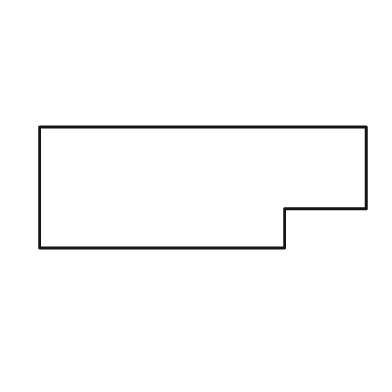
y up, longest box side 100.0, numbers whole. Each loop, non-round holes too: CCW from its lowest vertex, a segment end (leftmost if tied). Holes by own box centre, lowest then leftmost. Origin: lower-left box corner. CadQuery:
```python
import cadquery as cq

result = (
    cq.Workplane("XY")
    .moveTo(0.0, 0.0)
    .lineTo(75.0, 0.0)
    .lineTo(75.0, 12.0)
    .lineTo(100.0, 12.0)
    .lineTo(100.0, 37.0)
    .lineTo(0.0, 37.0)
    .close()
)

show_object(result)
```